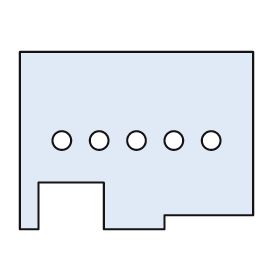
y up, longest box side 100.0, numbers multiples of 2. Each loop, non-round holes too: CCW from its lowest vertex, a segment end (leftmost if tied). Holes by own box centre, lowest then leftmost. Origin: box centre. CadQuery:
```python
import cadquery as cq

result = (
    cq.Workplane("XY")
    .moveTo(-50.0, -38.0)
    .lineTo(-42.0, -38.0)
    .lineTo(-42.0, -18.0)
    .lineTo(-14.0, -18.0)
    .lineTo(-14.0, -38.0)
    .lineTo(12.0, -38.0)
    .lineTo(12.0, -32.0)
    .lineTo(50.0, -32.0)
    .lineTo(50.0, 38.0)
    .lineTo(-50.0, 38.0)
    .close()
    .moveTo(-32.0, 0.0)
    .circle(4.0)
    .moveTo(-16.0, 0.0)
    .circle(4.0)
    .moveTo(0.0, 0.0)
    .circle(4.0)
    .moveTo(16.0, 0.0)
    .circle(4.0)
    .moveTo(32.0, 0.0)
    .circle(4.0)
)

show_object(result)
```